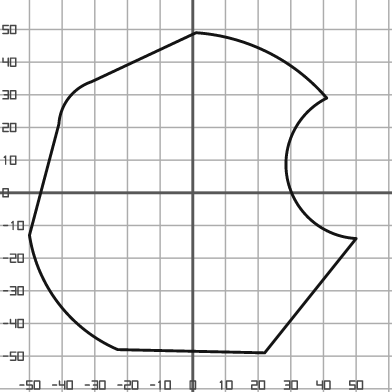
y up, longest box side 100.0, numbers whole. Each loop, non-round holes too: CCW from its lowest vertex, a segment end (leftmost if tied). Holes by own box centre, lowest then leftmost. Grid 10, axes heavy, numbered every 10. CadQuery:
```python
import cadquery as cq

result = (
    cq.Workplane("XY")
    .moveTo(22.0, -49.0)
    .lineTo(50.0, -14.0)
    .threePointArc((29.0, 4.0), (41.0, 29.0))
    .threePointArc((23.0, 43.0), (1.0, 49.0))
    .lineTo(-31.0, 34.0)
    .threePointArc((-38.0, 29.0), (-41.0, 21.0))
    .lineTo(-50.0, -13.0)
    .threePointArc((-41.0, -34.0), (-23.0, -48.0))
    .close()
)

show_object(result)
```